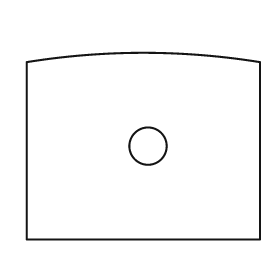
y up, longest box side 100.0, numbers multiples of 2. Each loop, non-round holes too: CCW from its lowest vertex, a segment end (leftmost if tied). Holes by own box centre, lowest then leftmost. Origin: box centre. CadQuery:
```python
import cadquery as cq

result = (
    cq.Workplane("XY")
    .moveTo(-50.0, -40.0)
    .lineTo(50.0, -40.0)
    .lineTo(50.0, 36.0)
    .threePointArc((0.0, 40.0), (-50.0, 36.0))
    .close()
    .moveTo(2.0, 0.0)
    .circle(8.0)
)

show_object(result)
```